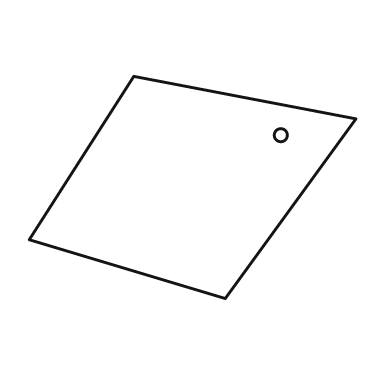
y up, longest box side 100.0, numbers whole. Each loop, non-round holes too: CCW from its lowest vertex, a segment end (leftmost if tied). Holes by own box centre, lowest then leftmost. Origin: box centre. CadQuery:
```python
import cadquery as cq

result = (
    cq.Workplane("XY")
    .moveTo(10.0, -34.0)
    .lineTo(50.0, 21.0)
    .lineTo(-18.0, 34.0)
    .lineTo(-50.0, -16.0)
    .close()
    .moveTo(27.0, 16.0)
    .circle(2.0)
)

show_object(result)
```